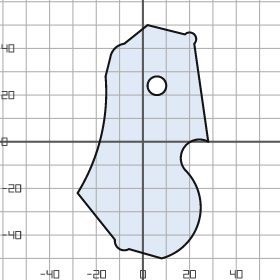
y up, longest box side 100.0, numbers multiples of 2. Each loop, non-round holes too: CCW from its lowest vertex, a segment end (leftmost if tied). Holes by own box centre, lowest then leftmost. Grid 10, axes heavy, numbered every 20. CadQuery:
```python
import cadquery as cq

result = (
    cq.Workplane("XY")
    .moveTo(8.0, -50.0)
    .threePointArc((24.0, -34.0), (18.0, -12.0))
    .threePointArc((18.0, -2.0), (28.0, 0.0))
    .lineTo(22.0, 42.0)
    .threePointArc((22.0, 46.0), (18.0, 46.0))
    .lineTo(2.0, 50.0)
    .lineTo(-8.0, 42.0)
    .threePointArc((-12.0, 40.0), (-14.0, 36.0))
    .lineTo(-16.0, 28.0)
    .threePointArc((-18.0, 2.0), (-28.0, -22.0))
    .lineTo(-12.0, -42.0)
    .threePointArc((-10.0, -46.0), (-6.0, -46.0))
    .close()
    .moveTo(6.0, 24.0)
    .circle(4.0)
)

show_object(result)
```